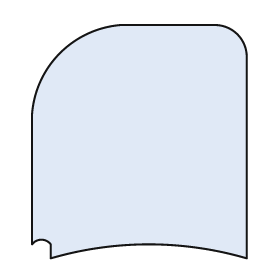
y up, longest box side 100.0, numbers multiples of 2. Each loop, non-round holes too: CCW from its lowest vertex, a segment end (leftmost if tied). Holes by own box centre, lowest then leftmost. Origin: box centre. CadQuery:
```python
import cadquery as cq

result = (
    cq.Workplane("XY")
    .moveTo(-38.0, -50.0)
    .threePointArc((4.0, -44.0), (46.0, -50.0))
    .lineTo(46.0, 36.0)
    .threePointArc((42.0, 46.0), (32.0, 50.0))
    .lineTo(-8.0, 50.0)
    .threePointArc((-34.0, 38.0), (-46.0, 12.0))
    .lineTo(-46.0, -44.0)
    .threePointArc((-42.0, -42.0), (-38.0, -44.0))
    .close()
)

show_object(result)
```